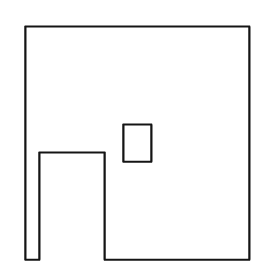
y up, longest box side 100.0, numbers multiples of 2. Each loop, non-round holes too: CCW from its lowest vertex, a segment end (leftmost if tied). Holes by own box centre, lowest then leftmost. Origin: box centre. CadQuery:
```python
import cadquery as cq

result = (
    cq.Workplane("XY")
    .moveTo(-48.0, -50.0)
    .lineTo(-42.0, -50.0)
    .lineTo(-42.0, -4.0)
    .lineTo(-14.0, -4.0)
    .lineTo(-14.0, -50.0)
    .lineTo(48.0, -50.0)
    .lineTo(48.0, 50.0)
    .lineTo(-48.0, 50.0)
    .close()
    .moveTo(-6.0, -8.0)
    .lineTo(6.0, -8.0)
    .lineTo(6.0, 8.0)
    .lineTo(-6.0, 8.0)
    .close()
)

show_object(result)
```